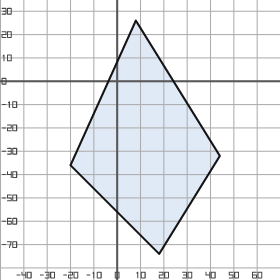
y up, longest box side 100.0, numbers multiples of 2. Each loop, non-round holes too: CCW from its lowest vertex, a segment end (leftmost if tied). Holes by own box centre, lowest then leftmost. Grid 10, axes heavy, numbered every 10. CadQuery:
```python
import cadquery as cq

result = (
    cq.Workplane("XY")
    .moveTo(18.0, -74.0)
    .lineTo(44.0, -32.0)
    .lineTo(8.0, 26.0)
    .lineTo(-20.0, -36.0)
    .close()
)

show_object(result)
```